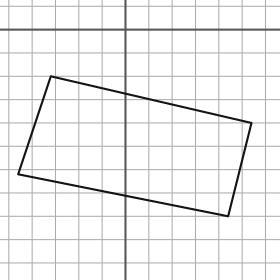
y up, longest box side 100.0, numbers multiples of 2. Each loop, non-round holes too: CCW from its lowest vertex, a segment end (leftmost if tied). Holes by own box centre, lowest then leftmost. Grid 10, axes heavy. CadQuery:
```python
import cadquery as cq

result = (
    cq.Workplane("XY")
    .moveTo(44.0, -80.0)
    .lineTo(54.0, -40.0)
    .lineTo(-32.0, -20.0)
    .lineTo(-46.0, -62.0)
    .close()
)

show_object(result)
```